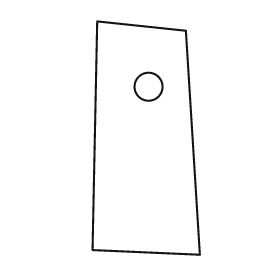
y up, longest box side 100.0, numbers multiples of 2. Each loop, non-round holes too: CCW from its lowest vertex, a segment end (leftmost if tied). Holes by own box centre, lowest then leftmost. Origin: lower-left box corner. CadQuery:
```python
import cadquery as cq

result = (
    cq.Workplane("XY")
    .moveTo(46.0, 0.0)
    .lineTo(40.0, 96.0)
    .lineTo(2.0, 100.0)
    .lineTo(0.0, 2.0)
    .close()
    .moveTo(24.0, 72.0)
    .circle(6.0)
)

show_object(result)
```